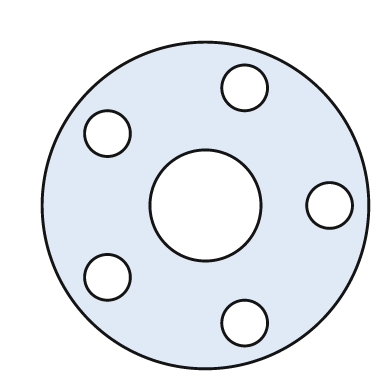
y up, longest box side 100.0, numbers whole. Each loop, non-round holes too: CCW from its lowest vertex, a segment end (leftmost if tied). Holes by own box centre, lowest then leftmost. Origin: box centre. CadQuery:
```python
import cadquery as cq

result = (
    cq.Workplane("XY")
    .moveTo(0.0, 0.0)
    .circle(50.0)
    .moveTo(12.0, -36.0)
    .circle(7.0)
    .moveTo(-30.0, -22.0)
    .circle(7.0)
    .moveTo(0.0, 0.0)
    .circle(17.0)
    .moveTo(38.0, 0.0)
    .circle(7.0)
    .moveTo(-30.0, 22.0)
    .circle(7.0)
    .moveTo(12.0, 36.0)
    .circle(7.0)
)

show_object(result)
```